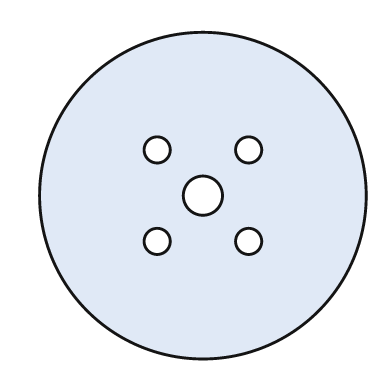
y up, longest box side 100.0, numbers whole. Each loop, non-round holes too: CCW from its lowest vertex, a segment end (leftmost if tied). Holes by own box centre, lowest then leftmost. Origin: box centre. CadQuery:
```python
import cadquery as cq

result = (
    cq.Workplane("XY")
    .moveTo(0.0, 0.0)
    .circle(50.0)
    .moveTo(-14.0, -14.0)
    .circle(4.0)
    .moveTo(14.0, -14.0)
    .circle(4.0)
    .moveTo(0.0, 0.0)
    .circle(6.0)
    .moveTo(-14.0, 14.0)
    .circle(4.0)
    .moveTo(14.0, 14.0)
    .circle(4.0)
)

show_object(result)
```